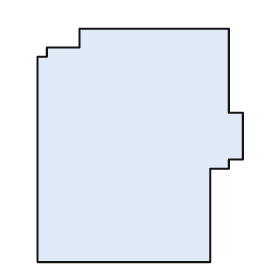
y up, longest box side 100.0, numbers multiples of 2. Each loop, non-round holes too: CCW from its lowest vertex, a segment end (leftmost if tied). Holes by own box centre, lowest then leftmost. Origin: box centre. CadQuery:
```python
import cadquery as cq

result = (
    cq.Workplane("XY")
    .moveTo(-44.0, -50.0)
    .lineTo(30.0, -50.0)
    .lineTo(30.0, -10.0)
    .lineTo(38.0, -10.0)
    .lineTo(38.0, -6.0)
    .lineTo(44.0, -6.0)
    .lineTo(44.0, 14.0)
    .lineTo(38.0, 14.0)
    .lineTo(38.0, 50.0)
    .lineTo(-26.0, 50.0)
    .lineTo(-26.0, 42.0)
    .lineTo(-40.0, 42.0)
    .lineTo(-40.0, 38.0)
    .lineTo(-44.0, 38.0)
    .close()
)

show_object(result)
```